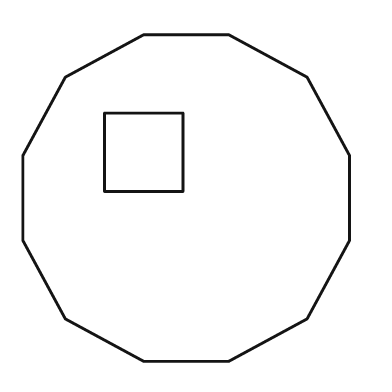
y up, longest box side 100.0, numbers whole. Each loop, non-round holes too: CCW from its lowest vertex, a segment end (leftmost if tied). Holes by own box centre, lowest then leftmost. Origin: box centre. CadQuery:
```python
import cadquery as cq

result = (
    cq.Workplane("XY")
    .moveTo(-13.0, -50.0)
    .lineTo(13.0, -50.0)
    .lineTo(37.0, -37.0)
    .lineTo(50.0, -13.0)
    .lineTo(50.0, 13.0)
    .lineTo(37.0, 37.0)
    .lineTo(13.0, 50.0)
    .lineTo(-13.0, 50.0)
    .lineTo(-37.0, 37.0)
    .lineTo(-50.0, 13.0)
    .lineTo(-50.0, -13.0)
    .lineTo(-37.0, -37.0)
    .close()
    .moveTo(-25.0, 2.0)
    .lineTo(-1.0, 2.0)
    .lineTo(-1.0, 26.0)
    .lineTo(-25.0, 26.0)
    .close()
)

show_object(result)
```